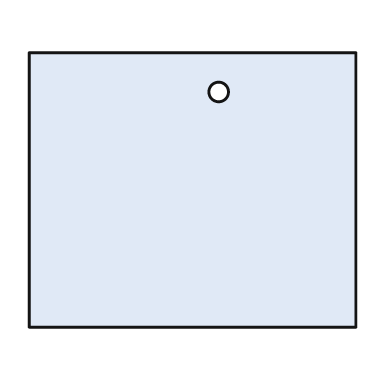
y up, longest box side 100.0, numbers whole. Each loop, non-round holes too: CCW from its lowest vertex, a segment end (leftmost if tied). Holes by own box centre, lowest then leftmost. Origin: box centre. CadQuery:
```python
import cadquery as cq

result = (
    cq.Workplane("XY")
    .moveTo(-50.0, -42.0)
    .lineTo(50.0, -42.0)
    .lineTo(50.0, 42.0)
    .lineTo(-50.0, 42.0)
    .close()
    .moveTo(8.0, 30.0)
    .circle(3.0)
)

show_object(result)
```